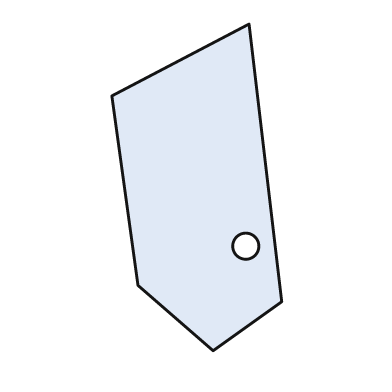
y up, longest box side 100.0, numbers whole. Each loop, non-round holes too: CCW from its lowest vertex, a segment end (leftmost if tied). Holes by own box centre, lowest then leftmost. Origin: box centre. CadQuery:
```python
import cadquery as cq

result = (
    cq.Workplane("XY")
    .moveTo(5.0, -50.0)
    .lineTo(26.0, -35.0)
    .lineTo(16.0, 50.0)
    .lineTo(-26.0, 28.0)
    .lineTo(-18.0, -30.0)
    .close()
    .moveTo(15.0, -18.0)
    .circle(4.0)
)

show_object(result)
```